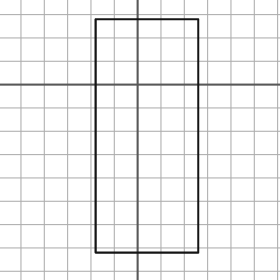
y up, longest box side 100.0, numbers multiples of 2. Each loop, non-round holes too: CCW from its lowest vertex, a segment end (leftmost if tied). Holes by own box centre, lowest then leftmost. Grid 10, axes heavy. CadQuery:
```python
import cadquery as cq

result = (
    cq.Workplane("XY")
    .moveTo(-18.0, -72.0)
    .lineTo(26.0, -72.0)
    .lineTo(26.0, 28.0)
    .lineTo(-18.0, 28.0)
    .close()
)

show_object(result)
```